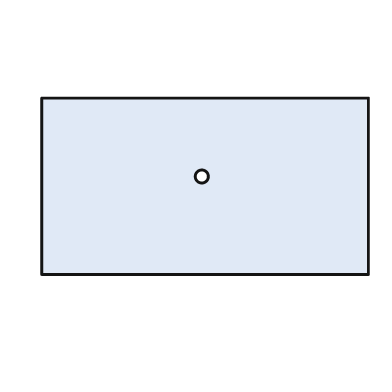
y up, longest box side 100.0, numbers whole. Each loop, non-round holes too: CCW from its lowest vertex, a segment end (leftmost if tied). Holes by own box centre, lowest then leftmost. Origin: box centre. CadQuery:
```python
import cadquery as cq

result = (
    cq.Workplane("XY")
    .moveTo(-50.0, -27.0)
    .lineTo(50.0, -27.0)
    .lineTo(50.0, 27.0)
    .lineTo(-50.0, 27.0)
    .close()
    .moveTo(-1.0, 3.0)
    .circle(2.0)
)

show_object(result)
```